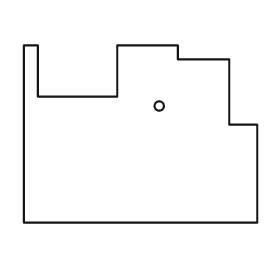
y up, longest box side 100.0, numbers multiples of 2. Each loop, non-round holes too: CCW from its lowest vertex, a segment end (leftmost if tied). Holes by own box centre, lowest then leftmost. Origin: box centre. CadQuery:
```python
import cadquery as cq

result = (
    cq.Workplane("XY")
    .moveTo(-50.0, -38.0)
    .lineTo(50.0, -38.0)
    .lineTo(50.0, 4.0)
    .lineTo(38.0, 4.0)
    .lineTo(38.0, 32.0)
    .lineTo(16.0, 32.0)
    .lineTo(16.0, 38.0)
    .lineTo(-10.0, 38.0)
    .lineTo(-10.0, 16.0)
    .lineTo(-44.0, 16.0)
    .lineTo(-44.0, 38.0)
    .lineTo(-50.0, 38.0)
    .close()
    .moveTo(8.0, 12.0)
    .circle(2.0)
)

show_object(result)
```